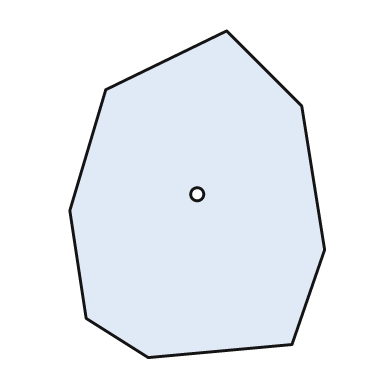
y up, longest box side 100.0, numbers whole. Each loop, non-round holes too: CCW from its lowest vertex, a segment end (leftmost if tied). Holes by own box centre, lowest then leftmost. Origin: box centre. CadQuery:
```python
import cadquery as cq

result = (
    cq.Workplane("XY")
    .moveTo(-15.0, -50.0)
    .lineTo(29.0, -46.0)
    .lineTo(39.0, -17.0)
    .lineTo(32.0, 27.0)
    .lineTo(9.0, 50.0)
    .lineTo(-28.0, 32.0)
    .lineTo(-39.0, -5.0)
    .lineTo(-34.0, -38.0)
    .close()
    .moveTo(0.0, 0.0)
    .circle(2.0)
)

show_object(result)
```